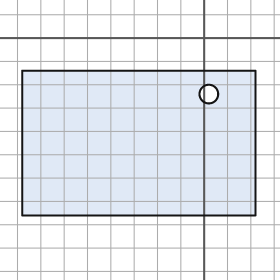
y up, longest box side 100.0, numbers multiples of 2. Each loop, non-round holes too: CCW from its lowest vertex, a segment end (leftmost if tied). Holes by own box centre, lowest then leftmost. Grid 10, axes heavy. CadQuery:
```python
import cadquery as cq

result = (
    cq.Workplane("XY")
    .moveTo(-78.0, -76.0)
    .lineTo(22.0, -76.0)
    .lineTo(22.0, -14.0)
    .lineTo(-78.0, -14.0)
    .close()
    .moveTo(2.0, -24.0)
    .circle(4.0)
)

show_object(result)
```